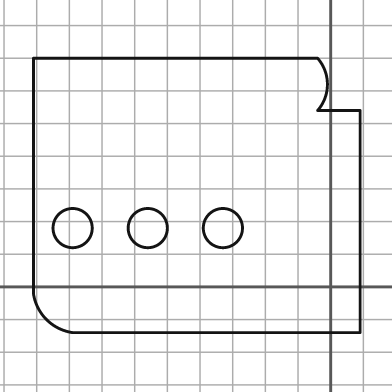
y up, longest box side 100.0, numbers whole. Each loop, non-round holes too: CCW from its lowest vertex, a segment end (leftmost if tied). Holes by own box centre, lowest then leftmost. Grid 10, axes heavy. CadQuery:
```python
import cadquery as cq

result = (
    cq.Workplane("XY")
    .moveTo(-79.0, -14.0)
    .lineTo(9.0, -14.0)
    .lineTo(9.0, 54.0)
    .lineTo(-4.0, 54.0)
    .threePointArc((-1.0, 62.0), (-4.0, 70.0))
    .lineTo(-91.0, 70.0)
    .lineTo(-91.0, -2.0)
    .threePointArc((-87.0, -10.0), (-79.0, -14.0))
    .close()
    .moveTo(-79.0, 18.0)
    .circle(6.0)
    .moveTo(-56.0, 18.0)
    .circle(6.0)
    .moveTo(-33.0, 18.0)
    .circle(6.0)
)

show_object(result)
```